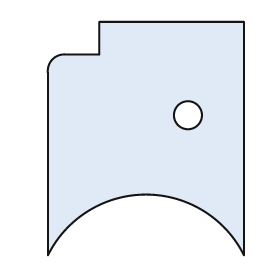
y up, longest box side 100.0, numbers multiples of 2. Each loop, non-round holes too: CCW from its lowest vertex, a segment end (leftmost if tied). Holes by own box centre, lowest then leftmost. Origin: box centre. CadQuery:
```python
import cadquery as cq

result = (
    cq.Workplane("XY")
    .moveTo(-42.0, -50.0)
    .threePointArc((0.0, -24.0), (42.0, -50.0))
    .lineTo(42.0, 50.0)
    .lineTo(-20.0, 50.0)
    .lineTo(-20.0, 36.0)
    .lineTo(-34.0, 36.0)
    .threePointArc((-40.0, 34.0), (-42.0, 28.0))
    .close()
    .moveTo(18.0, 10.0)
    .circle(6.0)
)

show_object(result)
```